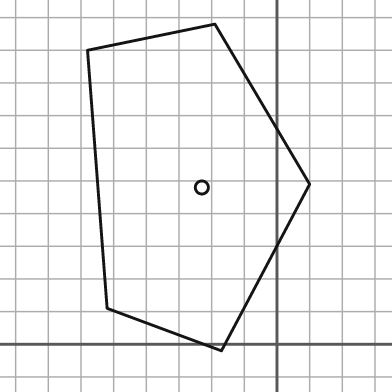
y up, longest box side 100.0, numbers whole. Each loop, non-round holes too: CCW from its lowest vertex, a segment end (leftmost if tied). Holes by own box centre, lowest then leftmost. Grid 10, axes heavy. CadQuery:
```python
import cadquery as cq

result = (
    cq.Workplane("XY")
    .moveTo(-17.0, -2.0)
    .lineTo(10.0, 49.0)
    .lineTo(-19.0, 98.0)
    .lineTo(-58.0, 90.0)
    .lineTo(-52.0, 11.0)
    .close()
    .moveTo(-23.0, 48.0)
    .circle(2.0)
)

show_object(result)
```